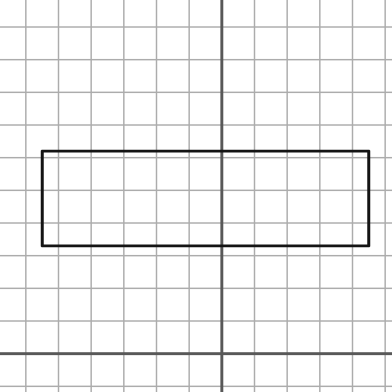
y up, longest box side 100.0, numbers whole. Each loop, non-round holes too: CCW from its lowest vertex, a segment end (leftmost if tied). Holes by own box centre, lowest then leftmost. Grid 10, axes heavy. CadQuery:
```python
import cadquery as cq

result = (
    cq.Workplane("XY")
    .moveTo(-55.0, 33.0)
    .lineTo(45.0, 33.0)
    .lineTo(45.0, 62.0)
    .lineTo(-55.0, 62.0)
    .close()
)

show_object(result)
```